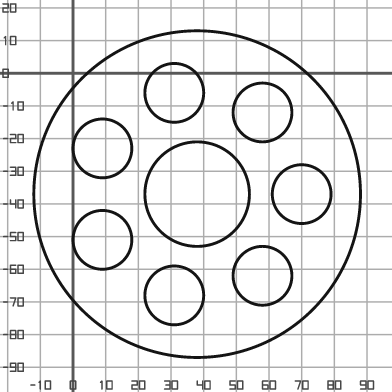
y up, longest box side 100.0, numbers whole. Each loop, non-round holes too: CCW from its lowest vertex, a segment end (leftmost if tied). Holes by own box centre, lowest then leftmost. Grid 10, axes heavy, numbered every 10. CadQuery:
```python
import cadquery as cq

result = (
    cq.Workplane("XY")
    .moveTo(38.0, -37.0)
    .circle(50.0)
    .moveTo(31.0, -68.0)
    .circle(9.0)
    .moveTo(58.0, -62.0)
    .circle(9.0)
    .moveTo(9.0, -51.0)
    .circle(9.0)
    .moveTo(38.0, -37.0)
    .circle(16.0)
    .moveTo(70.0, -37.0)
    .circle(9.0)
    .moveTo(9.0, -23.0)
    .circle(9.0)
    .moveTo(58.0, -12.0)
    .circle(9.0)
    .moveTo(31.0, -6.0)
    .circle(9.0)
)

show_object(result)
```